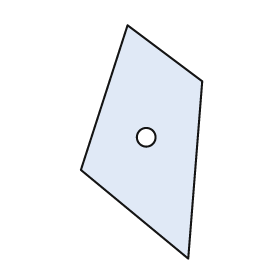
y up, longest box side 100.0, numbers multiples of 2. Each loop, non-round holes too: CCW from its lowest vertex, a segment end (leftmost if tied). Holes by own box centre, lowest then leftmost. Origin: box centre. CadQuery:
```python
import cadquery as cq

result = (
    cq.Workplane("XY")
    .moveTo(20.0, -50.0)
    .lineTo(26.0, 26.0)
    .lineTo(-6.0, 50.0)
    .lineTo(-26.0, -12.0)
    .close()
    .moveTo(2.0, 2.0)
    .circle(4.0)
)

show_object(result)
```